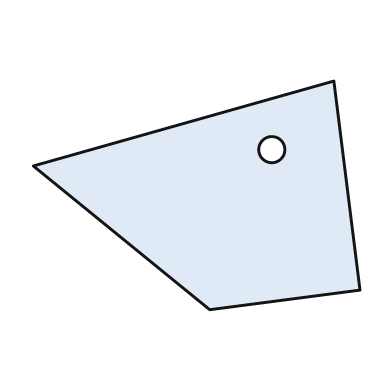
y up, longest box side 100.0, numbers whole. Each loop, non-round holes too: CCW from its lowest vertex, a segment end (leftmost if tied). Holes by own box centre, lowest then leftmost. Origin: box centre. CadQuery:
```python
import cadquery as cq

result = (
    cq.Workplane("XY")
    .moveTo(4.0, -35.0)
    .lineTo(50.0, -29.0)
    .lineTo(42.0, 35.0)
    .lineTo(-50.0, 9.0)
    .close()
    .moveTo(23.0, 14.0)
    .circle(4.0)
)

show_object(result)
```